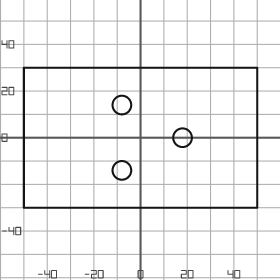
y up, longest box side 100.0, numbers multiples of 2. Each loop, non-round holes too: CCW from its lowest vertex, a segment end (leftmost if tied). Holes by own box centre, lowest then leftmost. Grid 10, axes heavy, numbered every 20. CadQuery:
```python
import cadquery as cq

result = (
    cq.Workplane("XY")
    .moveTo(-50.0, -30.0)
    .lineTo(50.0, -30.0)
    .lineTo(50.0, 30.0)
    .lineTo(-50.0, 30.0)
    .close()
    .moveTo(-8.0, -14.0)
    .circle(4.0)
    .moveTo(18.0, 0.0)
    .circle(4.0)
    .moveTo(-8.0, 14.0)
    .circle(4.0)
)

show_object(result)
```